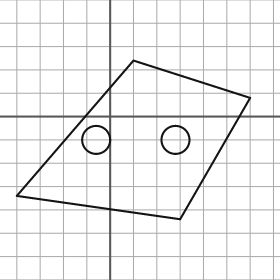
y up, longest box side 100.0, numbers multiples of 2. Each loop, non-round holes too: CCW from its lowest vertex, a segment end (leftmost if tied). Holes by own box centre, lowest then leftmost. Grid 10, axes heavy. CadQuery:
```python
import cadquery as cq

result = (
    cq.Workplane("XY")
    .moveTo(30.0, -44.0)
    .lineTo(60.0, 8.0)
    .lineTo(10.0, 24.0)
    .lineTo(-40.0, -34.0)
    .close()
    .moveTo(-6.0, -10.0)
    .circle(6.0)
    .moveTo(28.0, -10.0)
    .circle(6.0)
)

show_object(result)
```